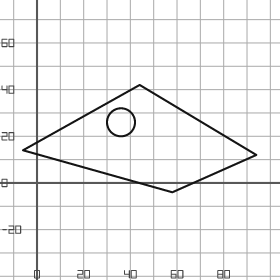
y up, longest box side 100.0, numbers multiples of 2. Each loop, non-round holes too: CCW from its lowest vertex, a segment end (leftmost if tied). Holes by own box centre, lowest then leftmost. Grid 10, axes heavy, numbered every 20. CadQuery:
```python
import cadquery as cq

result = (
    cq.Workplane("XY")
    .moveTo(58.0, -4.0)
    .lineTo(94.0, 12.0)
    .lineTo(44.0, 42.0)
    .lineTo(-6.0, 14.0)
    .close()
    .moveTo(36.0, 26.0)
    .circle(6.0)
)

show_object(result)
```